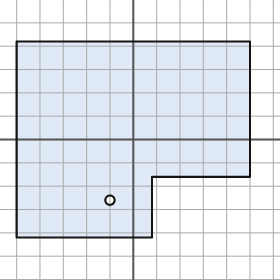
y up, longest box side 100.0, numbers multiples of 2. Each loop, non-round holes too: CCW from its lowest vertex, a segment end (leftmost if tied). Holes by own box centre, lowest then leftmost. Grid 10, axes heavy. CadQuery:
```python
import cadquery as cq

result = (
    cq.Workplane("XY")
    .moveTo(-50.0, -42.0)
    .lineTo(8.0, -42.0)
    .lineTo(8.0, -16.0)
    .lineTo(50.0, -16.0)
    .lineTo(50.0, 42.0)
    .lineTo(-50.0, 42.0)
    .close()
    .moveTo(-10.0, -26.0)
    .circle(2.0)
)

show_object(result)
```